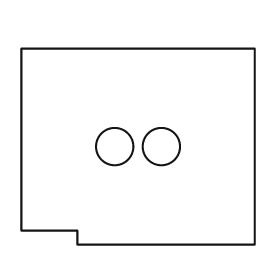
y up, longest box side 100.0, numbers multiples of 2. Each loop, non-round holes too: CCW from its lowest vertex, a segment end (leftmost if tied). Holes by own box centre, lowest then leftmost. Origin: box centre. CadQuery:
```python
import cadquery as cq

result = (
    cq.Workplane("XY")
    .moveTo(-26.0, -42.0)
    .lineTo(50.0, -42.0)
    .lineTo(50.0, 42.0)
    .lineTo(-50.0, 42.0)
    .lineTo(-50.0, -36.0)
    .lineTo(-26.0, -36.0)
    .close()
    .moveTo(-10.0, 0.0)
    .circle(8.0)
    .moveTo(10.0, 0.0)
    .circle(8.0)
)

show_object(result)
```